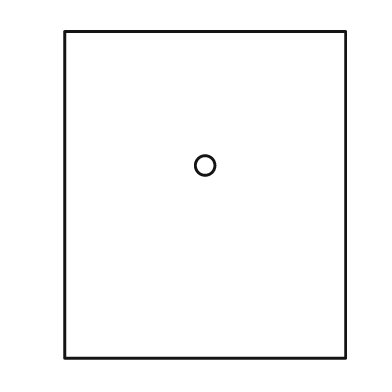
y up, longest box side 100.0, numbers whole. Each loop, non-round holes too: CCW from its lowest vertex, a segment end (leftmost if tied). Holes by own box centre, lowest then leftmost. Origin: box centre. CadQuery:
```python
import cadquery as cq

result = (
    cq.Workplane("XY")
    .moveTo(-43.0, -50.0)
    .lineTo(43.0, -50.0)
    .lineTo(43.0, 50.0)
    .lineTo(-43.0, 50.0)
    .close()
    .moveTo(0.0, 9.0)
    .circle(3.0)
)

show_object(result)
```